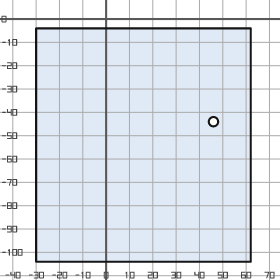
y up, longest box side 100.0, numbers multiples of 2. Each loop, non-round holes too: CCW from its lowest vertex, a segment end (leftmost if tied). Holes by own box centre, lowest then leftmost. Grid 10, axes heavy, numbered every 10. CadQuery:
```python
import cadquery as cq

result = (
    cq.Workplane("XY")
    .moveTo(-30.0, -104.0)
    .lineTo(62.0, -104.0)
    .lineTo(62.0, -4.0)
    .lineTo(-30.0, -4.0)
    .close()
    .moveTo(46.0, -44.0)
    .circle(2.0)
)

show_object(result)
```